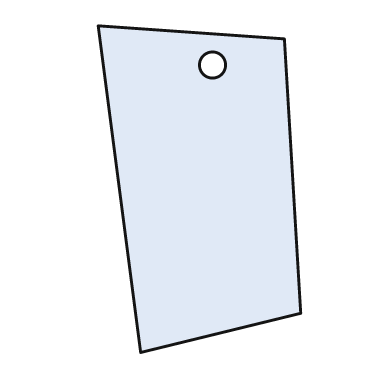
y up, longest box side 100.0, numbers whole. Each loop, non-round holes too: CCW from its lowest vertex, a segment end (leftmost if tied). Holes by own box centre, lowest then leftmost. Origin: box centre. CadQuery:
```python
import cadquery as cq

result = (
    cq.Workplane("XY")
    .moveTo(-18.0, -50.0)
    .lineTo(31.0, -38.0)
    .lineTo(26.0, 46.0)
    .lineTo(-31.0, 50.0)
    .close()
    .moveTo(4.0, 38.0)
    .circle(4.0)
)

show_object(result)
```